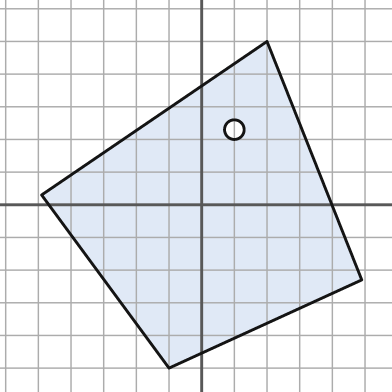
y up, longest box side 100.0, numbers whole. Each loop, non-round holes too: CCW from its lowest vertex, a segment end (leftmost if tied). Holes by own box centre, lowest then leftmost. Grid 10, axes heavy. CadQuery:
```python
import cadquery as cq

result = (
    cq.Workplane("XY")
    .moveTo(-10.0, -50.0)
    .lineTo(49.0, -23.0)
    .lineTo(20.0, 50.0)
    .lineTo(-49.0, 3.0)
    .close()
    .moveTo(10.0, 23.0)
    .circle(3.0)
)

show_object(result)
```